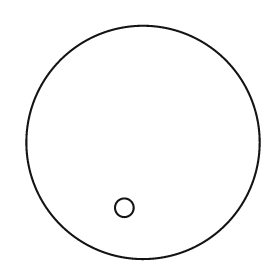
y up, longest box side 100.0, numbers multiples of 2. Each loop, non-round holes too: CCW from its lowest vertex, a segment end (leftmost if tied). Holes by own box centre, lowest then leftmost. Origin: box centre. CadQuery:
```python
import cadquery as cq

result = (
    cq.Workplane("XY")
    .moveTo(0.0, 0.0)
    .circle(50.0)
    .moveTo(-8.0, -28.0)
    .circle(4.0)
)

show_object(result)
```